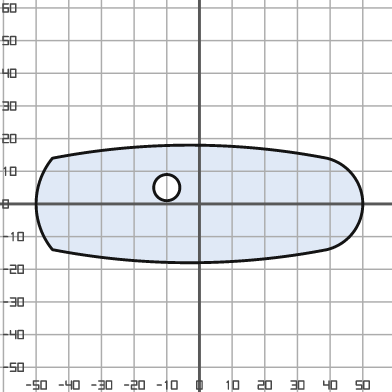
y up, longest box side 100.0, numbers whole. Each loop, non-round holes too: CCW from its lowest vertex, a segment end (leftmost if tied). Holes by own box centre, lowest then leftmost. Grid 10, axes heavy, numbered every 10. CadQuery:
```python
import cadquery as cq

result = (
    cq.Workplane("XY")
    .moveTo(-45.0, -14.0)
    .threePointArc((-3.0, -18.0), (39.0, -14.0))
    .threePointArc((50.0, 0.0), (39.0, 14.0))
    .threePointArc((-3.0, 18.0), (-45.0, 14.0))
    .threePointArc((-50.0, 0.0), (-45.0, -14.0))
    .close()
    .moveTo(-10.0, 5.0)
    .circle(4.0)
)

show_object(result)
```